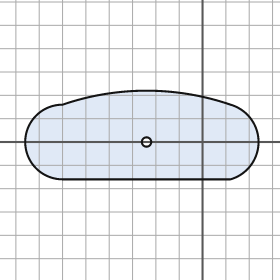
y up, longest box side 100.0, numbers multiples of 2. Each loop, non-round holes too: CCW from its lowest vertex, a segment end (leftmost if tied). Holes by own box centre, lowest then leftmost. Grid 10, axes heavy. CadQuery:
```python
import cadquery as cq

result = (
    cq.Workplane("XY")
    .moveTo(-60.0, -16.0)
    .lineTo(12.0, -16.0)
    .threePointArc((24.0, 0.0), (12.0, 16.0))
    .threePointArc((-24.0, 22.0), (-60.0, 16.0))
    .threePointArc((-76.0, 0.0), (-60.0, -16.0))
    .close()
    .moveTo(-24.0, 0.0)
    .circle(2.0)
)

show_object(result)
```